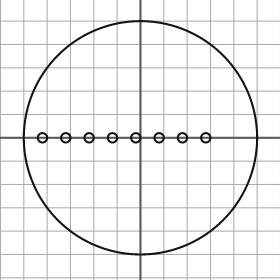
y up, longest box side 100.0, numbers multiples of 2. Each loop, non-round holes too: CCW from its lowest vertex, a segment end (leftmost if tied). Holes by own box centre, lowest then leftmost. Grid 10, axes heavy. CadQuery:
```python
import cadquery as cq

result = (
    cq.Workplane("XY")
    .moveTo(0.0, 0.0)
    .circle(50.0)
    .moveTo(-42.0, 0.0)
    .circle(2.0)
    .moveTo(-32.0, 0.0)
    .circle(2.0)
    .moveTo(-22.0, 0.0)
    .circle(2.0)
    .moveTo(-12.0, 0.0)
    .circle(2.0)
    .moveTo(-2.0, 0.0)
    .circle(2.0)
    .moveTo(8.0, 0.0)
    .circle(2.0)
    .moveTo(18.0, 0.0)
    .circle(2.0)
    .moveTo(28.0, 0.0)
    .circle(2.0)
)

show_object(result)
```